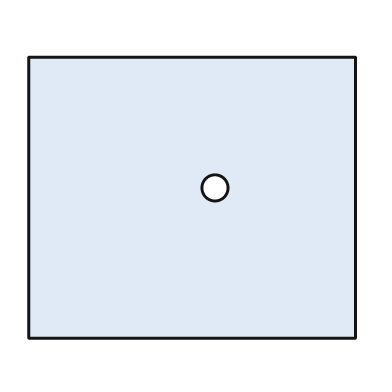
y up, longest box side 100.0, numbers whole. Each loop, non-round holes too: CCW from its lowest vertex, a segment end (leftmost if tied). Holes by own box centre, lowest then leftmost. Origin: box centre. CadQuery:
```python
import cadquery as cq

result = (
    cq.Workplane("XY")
    .moveTo(-50.0, -43.0)
    .lineTo(50.0, -43.0)
    .lineTo(50.0, 43.0)
    .lineTo(-50.0, 43.0)
    .close()
    .moveTo(7.0, 3.0)
    .circle(4.0)
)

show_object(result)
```